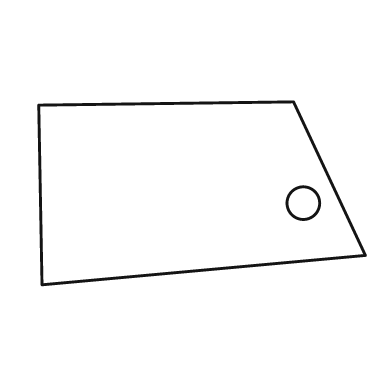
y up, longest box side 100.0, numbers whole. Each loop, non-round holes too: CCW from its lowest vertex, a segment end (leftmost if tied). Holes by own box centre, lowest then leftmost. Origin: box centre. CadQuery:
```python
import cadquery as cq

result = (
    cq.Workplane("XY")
    .moveTo(-49.0, -28.0)
    .lineTo(50.0, -19.0)
    .lineTo(28.0, 28.0)
    .lineTo(-50.0, 27.0)
    .close()
    .moveTo(31.0, -3.0)
    .circle(5.0)
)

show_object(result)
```